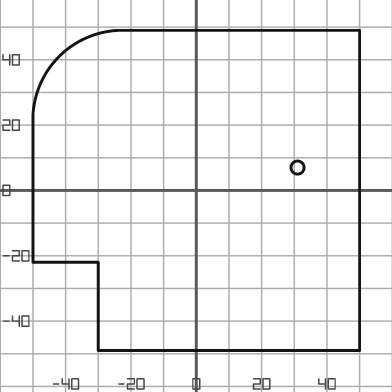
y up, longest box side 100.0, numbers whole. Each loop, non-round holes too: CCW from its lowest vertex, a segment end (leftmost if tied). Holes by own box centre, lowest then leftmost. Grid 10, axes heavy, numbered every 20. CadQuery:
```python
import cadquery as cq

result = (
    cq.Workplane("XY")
    .moveTo(-30.0, -49.0)
    .lineTo(50.0, -49.0)
    .lineTo(50.0, 49.0)
    .lineTo(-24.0, 49.0)
    .threePointArc((-42.0, 41.0), (-50.0, 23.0))
    .lineTo(-50.0, -22.0)
    .lineTo(-30.0, -22.0)
    .close()
    .moveTo(31.0, 7.0)
    .circle(2.0)
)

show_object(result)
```